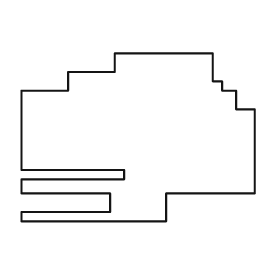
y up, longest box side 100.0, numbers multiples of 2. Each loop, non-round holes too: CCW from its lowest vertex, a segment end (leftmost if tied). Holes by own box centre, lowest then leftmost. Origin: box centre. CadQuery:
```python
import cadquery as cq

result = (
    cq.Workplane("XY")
    .moveTo(-50.0, -36.0)
    .lineTo(12.0, -36.0)
    .lineTo(12.0, -24.0)
    .lineTo(50.0, -24.0)
    .lineTo(50.0, 12.0)
    .lineTo(42.0, 12.0)
    .lineTo(42.0, 20.0)
    .lineTo(36.0, 20.0)
    .lineTo(36.0, 24.0)
    .lineTo(32.0, 24.0)
    .lineTo(32.0, 36.0)
    .lineTo(-10.0, 36.0)
    .lineTo(-10.0, 28.0)
    .lineTo(-30.0, 28.0)
    .lineTo(-30.0, 20.0)
    .lineTo(-50.0, 20.0)
    .lineTo(-50.0, -14.0)
    .lineTo(-6.0, -14.0)
    .lineTo(-6.0, -18.0)
    .lineTo(-50.0, -18.0)
    .lineTo(-50.0, -24.0)
    .lineTo(-12.0, -24.0)
    .lineTo(-12.0, -32.0)
    .lineTo(-50.0, -32.0)
    .close()
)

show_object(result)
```